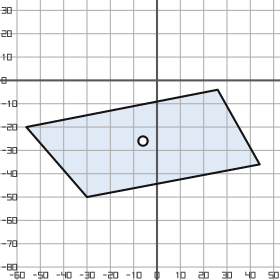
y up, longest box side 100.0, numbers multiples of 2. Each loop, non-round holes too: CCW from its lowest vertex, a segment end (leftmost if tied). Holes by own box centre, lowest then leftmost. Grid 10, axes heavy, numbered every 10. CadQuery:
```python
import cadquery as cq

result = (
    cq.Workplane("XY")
    .moveTo(-30.0, -50.0)
    .lineTo(44.0, -36.0)
    .lineTo(26.0, -4.0)
    .lineTo(-56.0, -20.0)
    .close()
    .moveTo(-6.0, -26.0)
    .circle(2.0)
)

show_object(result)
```